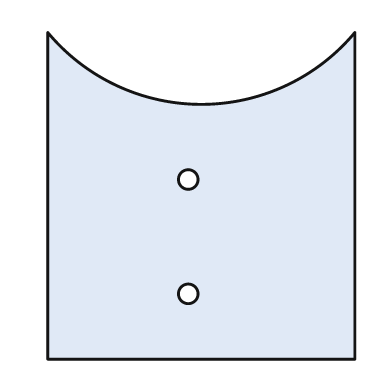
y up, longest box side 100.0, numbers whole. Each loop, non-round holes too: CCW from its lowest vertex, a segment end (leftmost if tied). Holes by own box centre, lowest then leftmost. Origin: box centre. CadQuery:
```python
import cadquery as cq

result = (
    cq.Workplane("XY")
    .moveTo(-47.0, -50.0)
    .lineTo(47.0, -50.0)
    .lineTo(47.0, 50.0)
    .threePointArc((0.0, 28.0), (-47.0, 50.0))
    .close()
    .moveTo(-4.0, -30.0)
    .circle(3.0)
    .moveTo(-4.0, 5.0)
    .circle(3.0)
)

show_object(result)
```